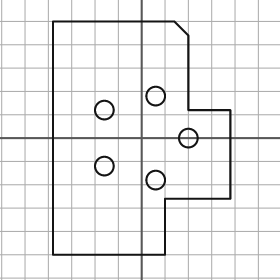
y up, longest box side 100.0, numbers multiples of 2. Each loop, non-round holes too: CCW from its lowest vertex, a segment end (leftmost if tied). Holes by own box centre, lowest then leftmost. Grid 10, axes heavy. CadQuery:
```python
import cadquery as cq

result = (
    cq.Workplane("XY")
    .moveTo(-38.0, -50.0)
    .lineTo(10.0, -50.0)
    .lineTo(10.0, -26.0)
    .lineTo(38.0, -26.0)
    .lineTo(38.0, 12.0)
    .lineTo(20.0, 12.0)
    .lineTo(20.0, 44.0)
    .lineTo(14.0, 50.0)
    .lineTo(-38.0, 50.0)
    .close()
    .moveTo(6.0, -18.0)
    .circle(4.0)
    .moveTo(-16.0, -12.0)
    .circle(4.0)
    .moveTo(20.0, 0.0)
    .circle(4.0)
    .moveTo(-16.0, 12.0)
    .circle(4.0)
    .moveTo(6.0, 18.0)
    .circle(4.0)
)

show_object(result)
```